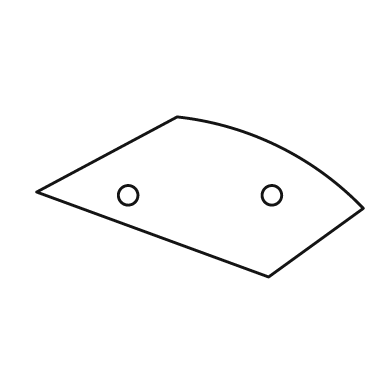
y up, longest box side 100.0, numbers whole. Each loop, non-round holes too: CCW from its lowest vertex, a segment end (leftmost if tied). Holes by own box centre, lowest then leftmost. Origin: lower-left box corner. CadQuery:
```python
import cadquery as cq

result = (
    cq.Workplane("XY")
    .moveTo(71.0, 0.0)
    .lineTo(100.0, 21.0)
    .threePointArc((74.0, 40.0), (43.0, 49.0))
    .lineTo(0.0, 26.0)
    .close()
    .moveTo(28.0, 25.0)
    .circle(3.0)
    .moveTo(72.0, 25.0)
    .circle(3.0)
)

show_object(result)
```